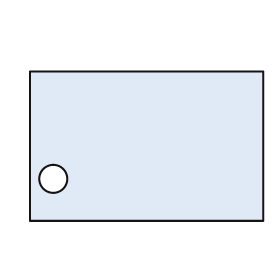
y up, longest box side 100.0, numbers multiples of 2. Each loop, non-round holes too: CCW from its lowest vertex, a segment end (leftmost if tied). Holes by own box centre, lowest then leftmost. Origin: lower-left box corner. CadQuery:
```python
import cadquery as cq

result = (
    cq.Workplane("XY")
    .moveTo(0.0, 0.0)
    .lineTo(100.0, 0.0)
    .lineTo(100.0, 64.0)
    .lineTo(0.0, 64.0)
    .close()
    .moveTo(10.0, 18.0)
    .circle(6.0)
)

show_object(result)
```